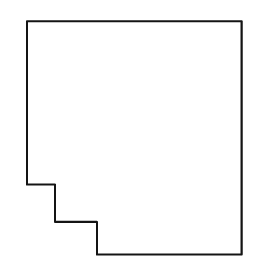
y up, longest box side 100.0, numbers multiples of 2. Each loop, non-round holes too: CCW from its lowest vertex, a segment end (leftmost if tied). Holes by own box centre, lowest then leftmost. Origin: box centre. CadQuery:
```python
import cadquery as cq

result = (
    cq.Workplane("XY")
    .moveTo(-16.0, -50.0)
    .lineTo(46.0, -50.0)
    .lineTo(46.0, 50.0)
    .lineTo(-46.0, 50.0)
    .lineTo(-46.0, -20.0)
    .lineTo(-34.0, -20.0)
    .lineTo(-34.0, -36.0)
    .lineTo(-16.0, -36.0)
    .close()
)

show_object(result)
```